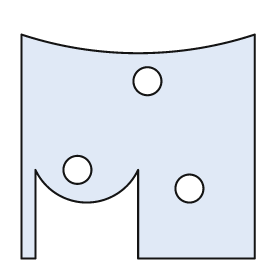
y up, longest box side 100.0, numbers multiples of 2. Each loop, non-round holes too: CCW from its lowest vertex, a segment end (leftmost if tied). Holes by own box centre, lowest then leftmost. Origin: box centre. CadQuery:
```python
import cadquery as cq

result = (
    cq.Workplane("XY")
    .moveTo(-50.0, -48.0)
    .lineTo(-44.0, -48.0)
    .lineTo(-44.0, -10.0)
    .threePointArc((-22.0, -24.0), (0.0, -10.0))
    .lineTo(0.0, -48.0)
    .lineTo(50.0, -48.0)
    .lineTo(50.0, 48.0)
    .threePointArc((0.0, 40.0), (-50.0, 48.0))
    .close()
    .moveTo(22.0, -18.0)
    .circle(6.0)
    .moveTo(-26.0, -10.0)
    .circle(6.0)
    .moveTo(4.0, 28.0)
    .circle(6.0)
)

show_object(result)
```